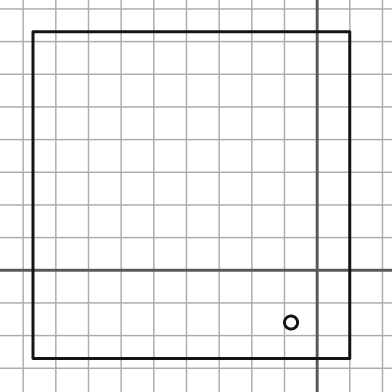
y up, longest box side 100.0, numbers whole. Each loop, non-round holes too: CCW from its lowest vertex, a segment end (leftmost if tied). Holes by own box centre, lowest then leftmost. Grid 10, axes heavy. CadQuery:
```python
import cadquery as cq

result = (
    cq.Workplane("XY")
    .moveTo(-87.0, -27.0)
    .lineTo(10.0, -27.0)
    .lineTo(10.0, 73.0)
    .lineTo(-87.0, 73.0)
    .close()
    .moveTo(-8.0, -16.0)
    .circle(2.0)
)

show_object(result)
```